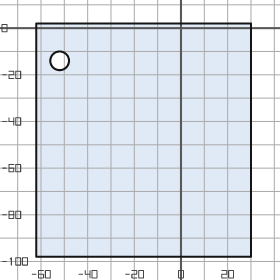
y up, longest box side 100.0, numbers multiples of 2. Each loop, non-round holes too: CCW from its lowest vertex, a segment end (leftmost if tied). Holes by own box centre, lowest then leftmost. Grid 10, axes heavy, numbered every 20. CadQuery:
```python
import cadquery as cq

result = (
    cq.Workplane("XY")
    .moveTo(-62.0, -98.0)
    .lineTo(30.0, -98.0)
    .lineTo(30.0, 2.0)
    .lineTo(-62.0, 2.0)
    .close()
    .moveTo(-52.0, -14.0)
    .circle(4.0)
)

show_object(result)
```